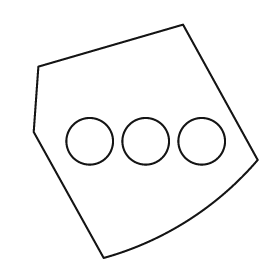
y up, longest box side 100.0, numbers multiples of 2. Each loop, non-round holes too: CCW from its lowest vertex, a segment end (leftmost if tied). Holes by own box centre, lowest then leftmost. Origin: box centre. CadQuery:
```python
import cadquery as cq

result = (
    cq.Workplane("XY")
    .moveTo(-18.0, -50.0)
    .threePointArc((18.0, -34.0), (48.0, -8.0))
    .lineTo(16.0, 50.0)
    .lineTo(-46.0, 32.0)
    .lineTo(-48.0, 4.0)
    .close()
    .moveTo(-24.0, 0.0)
    .circle(10.0)
    .moveTo(0.0, 0.0)
    .circle(10.0)
    .moveTo(24.0, 0.0)
    .circle(10.0)
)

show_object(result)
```